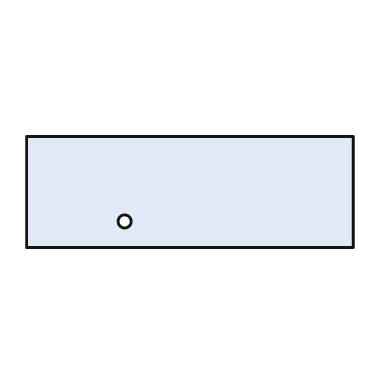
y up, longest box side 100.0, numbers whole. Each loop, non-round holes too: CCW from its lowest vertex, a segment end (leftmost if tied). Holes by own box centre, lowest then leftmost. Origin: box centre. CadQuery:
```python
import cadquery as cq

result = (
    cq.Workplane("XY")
    .moveTo(-50.0, -17.0)
    .lineTo(50.0, -17.0)
    .lineTo(50.0, 17.0)
    .lineTo(-50.0, 17.0)
    .close()
    .moveTo(-20.0, -9.0)
    .circle(2.0)
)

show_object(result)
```